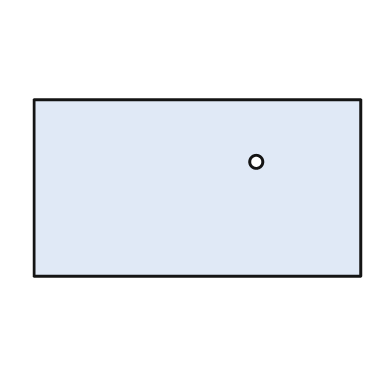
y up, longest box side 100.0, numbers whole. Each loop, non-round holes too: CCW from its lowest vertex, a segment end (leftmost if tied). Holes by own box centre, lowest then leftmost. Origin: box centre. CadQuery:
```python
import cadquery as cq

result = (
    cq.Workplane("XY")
    .moveTo(-50.0, -27.0)
    .lineTo(50.0, -27.0)
    .lineTo(50.0, 27.0)
    .lineTo(-50.0, 27.0)
    .close()
    .moveTo(18.0, 8.0)
    .circle(2.0)
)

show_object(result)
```